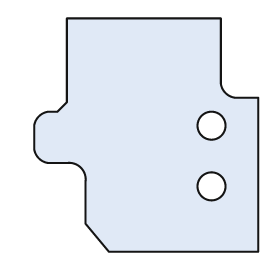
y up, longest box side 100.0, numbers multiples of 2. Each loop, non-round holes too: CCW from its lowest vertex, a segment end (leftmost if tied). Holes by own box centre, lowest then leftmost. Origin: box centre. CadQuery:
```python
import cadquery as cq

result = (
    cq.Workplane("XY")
    .moveTo(-16.0, -50.0)
    .lineTo(48.0, -50.0)
    .lineTo(48.0, 16.0)
    .lineTo(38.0, 16.0)
    .threePointArc((34.0, 18.0), (32.0, 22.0))
    .lineTo(32.0, 50.0)
    .lineTo(-34.0, 50.0)
    .lineTo(-34.0, 14.0)
    .lineTo(-38.0, 10.0)
    .lineTo(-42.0, 10.0)
    .threePointArc((-46.0, 8.0), (-48.0, 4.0))
    .lineTo(-48.0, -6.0)
    .threePointArc((-46.0, -10.0), (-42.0, -12.0))
    .lineTo(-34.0, -12.0)
    .threePointArc((-28.0, -14.0), (-26.0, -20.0))
    .lineTo(-26.0, -38.0)
    .close()
    .moveTo(28.0, -22.0)
    .circle(6.0)
    .moveTo(28.0, 4.0)
    .circle(6.0)
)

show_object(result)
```